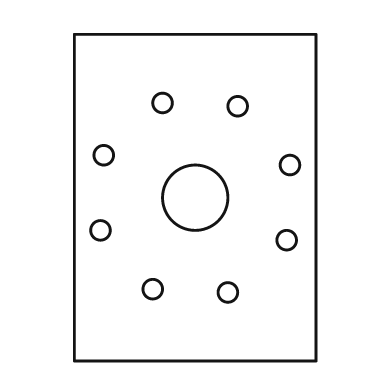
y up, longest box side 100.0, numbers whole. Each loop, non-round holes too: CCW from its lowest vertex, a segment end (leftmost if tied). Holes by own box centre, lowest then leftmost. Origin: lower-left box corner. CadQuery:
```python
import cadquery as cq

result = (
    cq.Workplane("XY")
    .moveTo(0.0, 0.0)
    .lineTo(74.0, 0.0)
    .lineTo(74.0, 100.0)
    .lineTo(0.0, 100.0)
    .close()
    .moveTo(47.0, 21.0)
    .circle(3.0)
    .moveTo(24.0, 22.0)
    .circle(3.0)
    .moveTo(65.0, 37.0)
    .circle(3.0)
    .moveTo(8.0, 40.0)
    .circle(3.0)
    .moveTo(37.0, 50.0)
    .circle(10.0)
    .moveTo(66.0, 60.0)
    .circle(3.0)
    .moveTo(9.0, 63.0)
    .circle(3.0)
    .moveTo(50.0, 78.0)
    .circle(3.0)
    .moveTo(27.0, 79.0)
    .circle(3.0)
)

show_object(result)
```